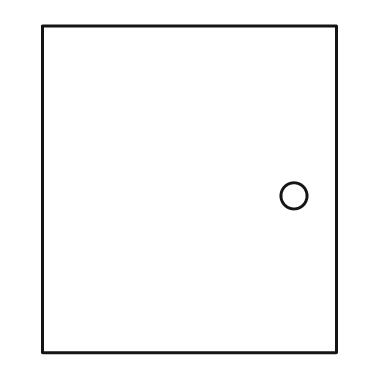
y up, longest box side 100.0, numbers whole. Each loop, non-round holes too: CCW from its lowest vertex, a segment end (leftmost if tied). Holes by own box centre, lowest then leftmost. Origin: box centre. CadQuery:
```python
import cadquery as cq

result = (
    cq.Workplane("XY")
    .moveTo(-45.0, -50.0)
    .lineTo(45.0, -50.0)
    .lineTo(45.0, 50.0)
    .lineTo(-45.0, 50.0)
    .close()
    .moveTo(32.0, -2.0)
    .circle(4.0)
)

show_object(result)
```